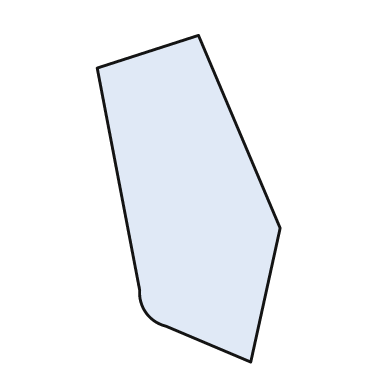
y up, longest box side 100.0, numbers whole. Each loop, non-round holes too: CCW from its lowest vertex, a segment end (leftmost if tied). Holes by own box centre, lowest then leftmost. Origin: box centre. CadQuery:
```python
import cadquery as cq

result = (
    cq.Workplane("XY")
    .moveTo(19.0, -50.0)
    .lineTo(28.0, -9.0)
    .lineTo(3.0, 50.0)
    .lineTo(-28.0, 40.0)
    .lineTo(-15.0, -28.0)
    .threePointArc((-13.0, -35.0), (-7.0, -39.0))
    .close()
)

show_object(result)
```